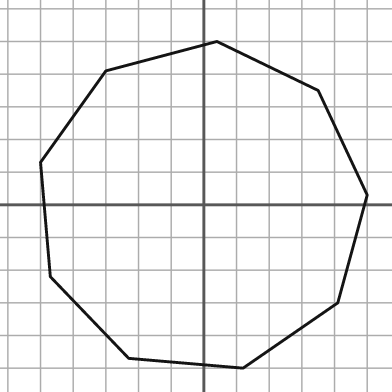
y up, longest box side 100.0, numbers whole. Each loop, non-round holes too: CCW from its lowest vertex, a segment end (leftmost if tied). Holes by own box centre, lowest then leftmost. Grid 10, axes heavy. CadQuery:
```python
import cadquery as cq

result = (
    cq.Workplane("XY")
    .moveTo(12.0, -50.0)
    .lineTo(41.0, -30.0)
    .lineTo(50.0, 3.0)
    .lineTo(35.0, 35.0)
    .lineTo(4.0, 50.0)
    .lineTo(-30.0, 41.0)
    .lineTo(-50.0, 13.0)
    .lineTo(-47.0, -22.0)
    .lineTo(-23.0, -47.0)
    .close()
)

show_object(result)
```